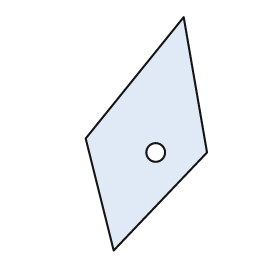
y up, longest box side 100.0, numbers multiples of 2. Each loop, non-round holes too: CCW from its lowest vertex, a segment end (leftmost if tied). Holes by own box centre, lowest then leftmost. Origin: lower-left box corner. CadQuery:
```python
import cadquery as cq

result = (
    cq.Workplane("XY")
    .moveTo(12.0, 0.0)
    .lineTo(52.0, 42.0)
    .lineTo(42.0, 100.0)
    .lineTo(0.0, 48.0)
    .close()
    .moveTo(30.0, 42.0)
    .circle(4.0)
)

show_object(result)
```